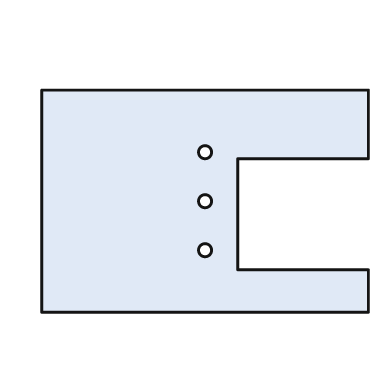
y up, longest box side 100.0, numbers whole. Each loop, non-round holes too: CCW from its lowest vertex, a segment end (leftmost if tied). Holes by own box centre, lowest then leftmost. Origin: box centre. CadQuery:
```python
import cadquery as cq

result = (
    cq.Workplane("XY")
    .moveTo(-50.0, -34.0)
    .lineTo(50.0, -34.0)
    .lineTo(50.0, -21.0)
    .lineTo(10.0, -21.0)
    .lineTo(10.0, 13.0)
    .lineTo(50.0, 13.0)
    .lineTo(50.0, 34.0)
    .lineTo(-50.0, 34.0)
    .close()
    .moveTo(0.0, -15.0)
    .circle(2.0)
    .moveTo(0.0, 0.0)
    .circle(2.0)
    .moveTo(0.0, 15.0)
    .circle(2.0)
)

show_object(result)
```